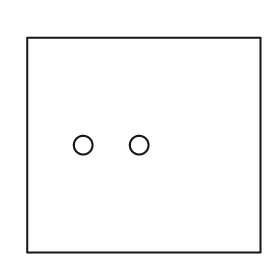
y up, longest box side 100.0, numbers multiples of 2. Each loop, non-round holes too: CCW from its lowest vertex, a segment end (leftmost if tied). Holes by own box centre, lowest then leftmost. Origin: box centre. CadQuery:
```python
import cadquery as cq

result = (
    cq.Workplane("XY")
    .moveTo(-50.0, -46.0)
    .lineTo(50.0, -46.0)
    .lineTo(50.0, 46.0)
    .lineTo(-50.0, 46.0)
    .close()
    .moveTo(-26.0, 0.0)
    .circle(4.0)
    .moveTo(-2.0, 0.0)
    .circle(4.0)
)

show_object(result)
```